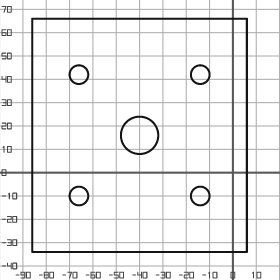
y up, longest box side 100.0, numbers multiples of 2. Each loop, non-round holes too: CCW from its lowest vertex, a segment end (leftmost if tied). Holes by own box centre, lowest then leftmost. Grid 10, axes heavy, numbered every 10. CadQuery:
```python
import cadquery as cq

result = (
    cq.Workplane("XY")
    .moveTo(-86.0, -34.0)
    .lineTo(6.0, -34.0)
    .lineTo(6.0, 66.0)
    .lineTo(-86.0, 66.0)
    .close()
    .moveTo(-66.0, -10.0)
    .circle(4.0)
    .moveTo(-14.0, -10.0)
    .circle(4.0)
    .moveTo(-40.0, 16.0)
    .circle(8.0)
    .moveTo(-66.0, 42.0)
    .circle(4.0)
    .moveTo(-14.0, 42.0)
    .circle(4.0)
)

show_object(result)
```